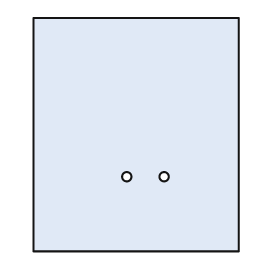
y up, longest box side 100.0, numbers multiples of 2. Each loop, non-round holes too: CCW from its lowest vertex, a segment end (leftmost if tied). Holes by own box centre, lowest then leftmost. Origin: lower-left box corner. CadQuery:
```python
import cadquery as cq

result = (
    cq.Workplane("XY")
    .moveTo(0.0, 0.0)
    .lineTo(88.0, 0.0)
    .lineTo(88.0, 100.0)
    .lineTo(0.0, 100.0)
    .close()
    .moveTo(40.0, 32.0)
    .circle(2.0)
    .moveTo(56.0, 32.0)
    .circle(2.0)
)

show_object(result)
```